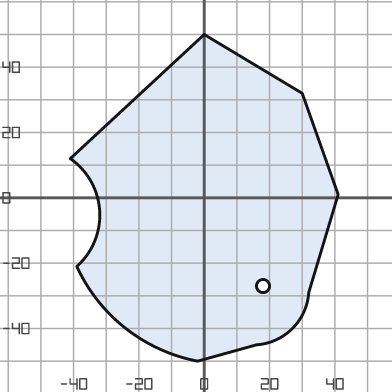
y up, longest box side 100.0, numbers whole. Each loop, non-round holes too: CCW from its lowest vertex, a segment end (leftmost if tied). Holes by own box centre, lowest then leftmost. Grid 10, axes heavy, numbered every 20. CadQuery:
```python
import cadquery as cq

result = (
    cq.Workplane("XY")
    .moveTo(-2.0, -50.0)
    .lineTo(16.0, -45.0)
    .threePointArc((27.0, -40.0), (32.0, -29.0))
    .lineTo(41.0, 1.0)
    .lineTo(30.0, 32.0)
    .lineTo(0.0, 50.0)
    .lineTo(-41.0, 12.0)
    .threePointArc((-32.0, -4.0), (-39.0, -21.0))
    .threePointArc((-24.0, -40.0), (-2.0, -50.0))
    .close()
    .moveTo(18.0, -27.0)
    .circle(2.0)
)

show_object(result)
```